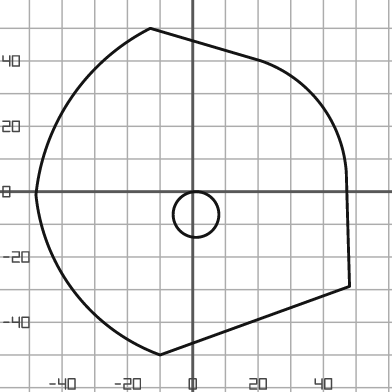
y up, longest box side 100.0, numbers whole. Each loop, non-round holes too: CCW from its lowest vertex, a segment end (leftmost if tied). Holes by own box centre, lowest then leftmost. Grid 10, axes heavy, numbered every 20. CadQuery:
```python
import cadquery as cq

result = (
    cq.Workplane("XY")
    .moveTo(-10.0, -50.0)
    .lineTo(48.0, -29.0)
    .lineTo(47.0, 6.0)
    .threePointArc((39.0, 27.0), (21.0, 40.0))
    .lineTo(-13.0, 50.0)
    .threePointArc((-37.0, 29.0), (-48.0, -1.0))
    .threePointArc((-36.0, -31.0), (-10.0, -50.0))
    .close()
    .moveTo(1.0, -7.0)
    .circle(7.0)
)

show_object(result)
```